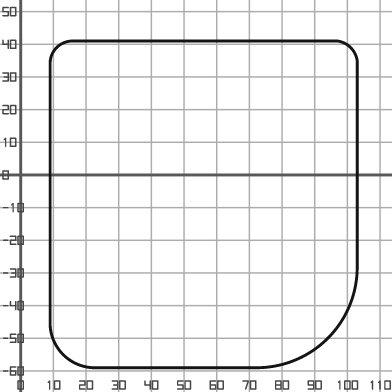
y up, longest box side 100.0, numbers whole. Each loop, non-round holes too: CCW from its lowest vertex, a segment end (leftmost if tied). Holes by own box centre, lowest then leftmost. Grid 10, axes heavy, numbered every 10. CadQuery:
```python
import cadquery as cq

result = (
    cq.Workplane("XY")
    .moveTo(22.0, -59.0)
    .lineTo(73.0, -59.0)
    .threePointArc((94.0, -50.0), (103.0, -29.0))
    .lineTo(103.0, 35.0)
    .threePointArc((101.0, 39.0), (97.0, 41.0))
    .lineTo(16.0, 41.0)
    .threePointArc((11.0, 39.0), (9.0, 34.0))
    .lineTo(9.0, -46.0)
    .threePointArc((13.0, -55.0), (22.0, -59.0))
    .close()
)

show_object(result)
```